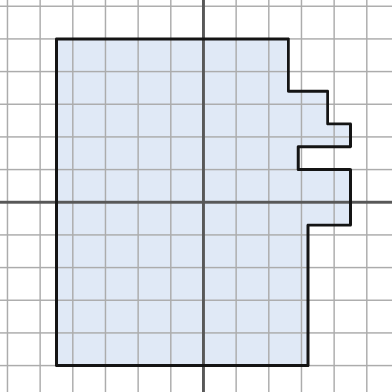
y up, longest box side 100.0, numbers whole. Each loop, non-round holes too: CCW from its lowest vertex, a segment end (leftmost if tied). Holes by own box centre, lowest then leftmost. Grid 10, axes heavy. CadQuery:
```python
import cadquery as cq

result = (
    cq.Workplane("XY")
    .moveTo(-45.0, -50.0)
    .lineTo(32.0, -50.0)
    .lineTo(32.0, -7.0)
    .lineTo(45.0, -7.0)
    .lineTo(45.0, 10.0)
    .lineTo(29.0, 10.0)
    .lineTo(29.0, 17.0)
    .lineTo(45.0, 17.0)
    .lineTo(45.0, 24.0)
    .lineTo(38.0, 24.0)
    .lineTo(38.0, 34.0)
    .lineTo(26.0, 34.0)
    .lineTo(26.0, 50.0)
    .lineTo(-45.0, 50.0)
    .close()
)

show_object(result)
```